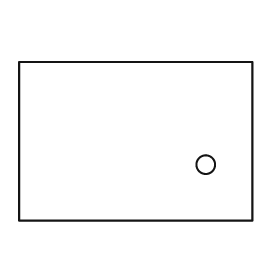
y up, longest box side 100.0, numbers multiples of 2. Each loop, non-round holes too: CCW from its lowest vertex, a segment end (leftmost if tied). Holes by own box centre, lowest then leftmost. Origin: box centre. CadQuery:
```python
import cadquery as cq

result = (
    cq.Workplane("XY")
    .moveTo(-50.0, -34.0)
    .lineTo(50.0, -34.0)
    .lineTo(50.0, 34.0)
    .lineTo(-50.0, 34.0)
    .close()
    .moveTo(30.0, -10.0)
    .circle(4.0)
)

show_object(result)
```